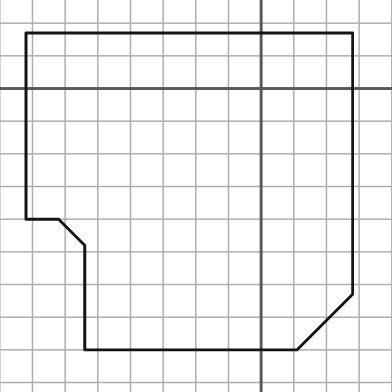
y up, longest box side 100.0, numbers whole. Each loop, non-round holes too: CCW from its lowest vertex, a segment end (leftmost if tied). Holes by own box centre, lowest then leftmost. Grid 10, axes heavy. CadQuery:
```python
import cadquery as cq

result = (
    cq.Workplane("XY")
    .moveTo(-54.0, -80.0)
    .lineTo(11.0, -80.0)
    .lineTo(28.0, -63.0)
    .lineTo(28.0, 17.0)
    .lineTo(-72.0, 17.0)
    .lineTo(-72.0, -40.0)
    .lineTo(-62.0, -40.0)
    .lineTo(-54.0, -48.0)
    .close()
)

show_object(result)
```